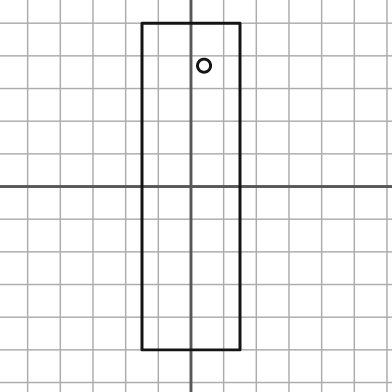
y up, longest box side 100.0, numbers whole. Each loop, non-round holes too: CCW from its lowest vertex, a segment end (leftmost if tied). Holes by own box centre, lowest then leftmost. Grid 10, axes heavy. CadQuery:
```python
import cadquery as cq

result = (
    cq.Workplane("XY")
    .moveTo(-15.0, -50.0)
    .lineTo(15.0, -50.0)
    .lineTo(15.0, 50.0)
    .lineTo(-15.0, 50.0)
    .close()
    .moveTo(4.0, 37.0)
    .circle(2.0)
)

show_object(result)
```